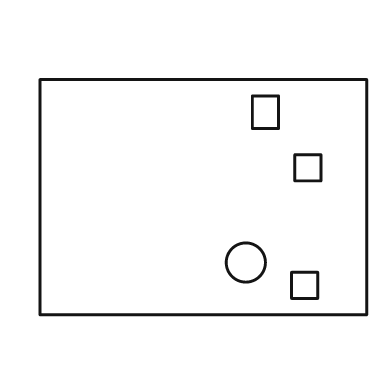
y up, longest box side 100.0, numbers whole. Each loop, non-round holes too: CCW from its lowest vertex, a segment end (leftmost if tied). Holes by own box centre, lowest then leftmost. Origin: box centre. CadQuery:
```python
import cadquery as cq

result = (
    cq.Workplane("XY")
    .moveTo(-50.0, -36.0)
    .lineTo(50.0, -36.0)
    .lineTo(50.0, 36.0)
    .lineTo(-50.0, 36.0)
    .close()
    .moveTo(27.0, -31.0)
    .lineTo(35.0, -31.0)
    .lineTo(35.0, -23.0)
    .lineTo(27.0, -23.0)
    .close()
    .moveTo(13.0, -20.0)
    .circle(6.0)
    .moveTo(28.0, 5.0)
    .lineTo(36.0, 5.0)
    .lineTo(36.0, 13.0)
    .lineTo(28.0, 13.0)
    .close()
    .moveTo(15.0, 21.0)
    .lineTo(23.0, 21.0)
    .lineTo(23.0, 31.0)
    .lineTo(15.0, 31.0)
    .close()
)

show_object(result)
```